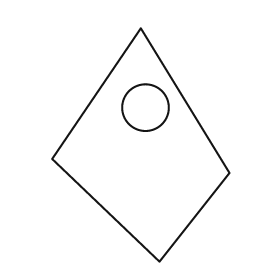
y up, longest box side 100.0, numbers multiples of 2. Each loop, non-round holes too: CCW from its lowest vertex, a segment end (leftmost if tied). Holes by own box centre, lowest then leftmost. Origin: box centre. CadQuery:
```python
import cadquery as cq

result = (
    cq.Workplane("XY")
    .moveTo(8.0, -50.0)
    .lineTo(38.0, -12.0)
    .lineTo(0.0, 50.0)
    .lineTo(-38.0, -6.0)
    .close()
    .moveTo(2.0, 16.0)
    .circle(10.0)
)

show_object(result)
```